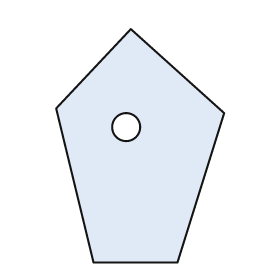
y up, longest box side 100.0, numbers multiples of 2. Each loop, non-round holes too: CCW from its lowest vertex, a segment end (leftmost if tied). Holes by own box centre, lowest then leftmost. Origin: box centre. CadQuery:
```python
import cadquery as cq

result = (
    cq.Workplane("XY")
    .moveTo(-20.0, -50.0)
    .lineTo(16.0, -50.0)
    .lineTo(36.0, 14.0)
    .lineTo(-4.0, 50.0)
    .lineTo(-36.0, 16.0)
    .close()
    .moveTo(-6.0, 8.0)
    .circle(6.0)
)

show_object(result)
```